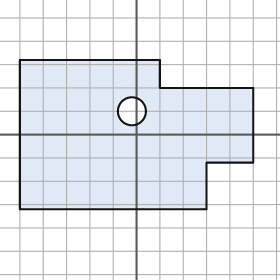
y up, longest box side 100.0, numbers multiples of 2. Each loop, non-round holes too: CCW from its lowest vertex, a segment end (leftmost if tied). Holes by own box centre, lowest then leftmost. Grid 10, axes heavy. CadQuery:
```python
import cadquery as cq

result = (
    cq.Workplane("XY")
    .moveTo(-50.0, -32.0)
    .lineTo(30.0, -32.0)
    .lineTo(30.0, -12.0)
    .lineTo(50.0, -12.0)
    .lineTo(50.0, 20.0)
    .lineTo(10.0, 20.0)
    .lineTo(10.0, 32.0)
    .lineTo(-50.0, 32.0)
    .close()
    .moveTo(-2.0, 10.0)
    .circle(6.0)
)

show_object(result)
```